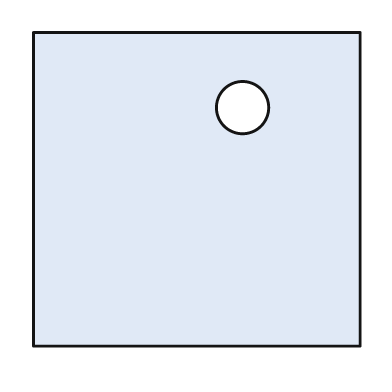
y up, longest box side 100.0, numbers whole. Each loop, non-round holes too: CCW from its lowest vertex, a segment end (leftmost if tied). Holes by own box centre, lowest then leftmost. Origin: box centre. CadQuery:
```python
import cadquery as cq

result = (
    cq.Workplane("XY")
    .moveTo(-50.0, -48.0)
    .lineTo(50.0, -48.0)
    .lineTo(50.0, 48.0)
    .lineTo(-50.0, 48.0)
    .close()
    .moveTo(14.0, 25.0)
    .circle(8.0)
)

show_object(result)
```